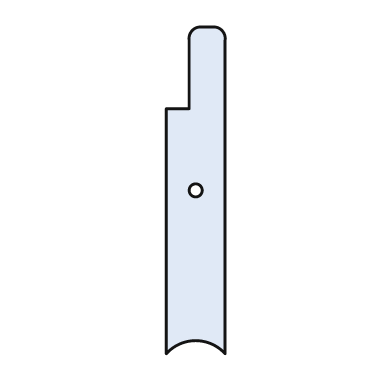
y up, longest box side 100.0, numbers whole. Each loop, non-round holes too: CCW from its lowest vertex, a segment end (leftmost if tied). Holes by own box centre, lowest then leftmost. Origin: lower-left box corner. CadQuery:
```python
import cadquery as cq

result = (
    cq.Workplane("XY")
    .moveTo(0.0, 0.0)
    .threePointArc((9.0, 4.0), (18.0, 0.0))
    .lineTo(18.0, 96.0)
    .threePointArc((17.0, 99.0), (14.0, 100.0))
    .lineTo(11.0, 100.0)
    .threePointArc((8.0, 99.0), (7.0, 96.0))
    .lineTo(7.0, 75.0)
    .lineTo(0.0, 75.0)
    .close()
    .moveTo(9.0, 50.0)
    .circle(2.0)
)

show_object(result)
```